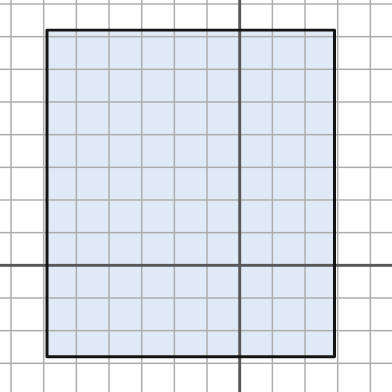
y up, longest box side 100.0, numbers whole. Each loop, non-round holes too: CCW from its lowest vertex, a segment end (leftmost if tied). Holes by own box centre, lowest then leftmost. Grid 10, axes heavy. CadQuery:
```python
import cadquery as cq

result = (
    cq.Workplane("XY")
    .moveTo(-59.0, -28.0)
    .lineTo(29.0, -28.0)
    .lineTo(29.0, 72.0)
    .lineTo(-59.0, 72.0)
    .close()
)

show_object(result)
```